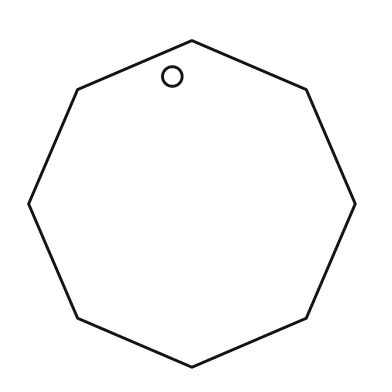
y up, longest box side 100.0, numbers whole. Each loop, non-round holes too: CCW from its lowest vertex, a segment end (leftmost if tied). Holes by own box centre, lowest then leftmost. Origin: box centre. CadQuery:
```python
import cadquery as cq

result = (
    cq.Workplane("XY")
    .moveTo(0.0, -50.0)
    .lineTo(35.0, -35.0)
    .lineTo(50.0, 0.0)
    .lineTo(35.0, 35.0)
    .lineTo(0.0, 50.0)
    .lineTo(-35.0, 35.0)
    .lineTo(-50.0, 0.0)
    .lineTo(-35.0, -35.0)
    .close()
    .moveTo(-6.0, 39.0)
    .circle(3.0)
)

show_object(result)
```